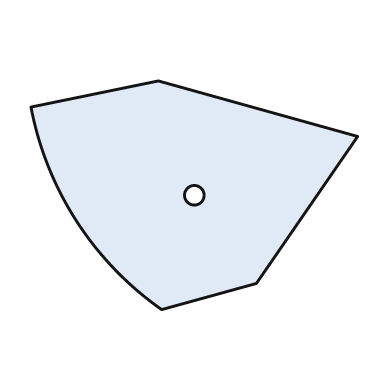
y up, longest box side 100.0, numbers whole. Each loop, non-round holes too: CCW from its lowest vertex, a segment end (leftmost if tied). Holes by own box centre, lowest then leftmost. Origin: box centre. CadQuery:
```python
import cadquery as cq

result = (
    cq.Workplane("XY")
    .moveTo(-10.0, -35.0)
    .lineTo(19.0, -27.0)
    .lineTo(50.0, 18.0)
    .lineTo(-11.0, 35.0)
    .lineTo(-50.0, 27.0)
    .threePointArc((-36.0, -8.0), (-10.0, -35.0))
    .close()
    .moveTo(0.0, 0.0)
    .circle(3.0)
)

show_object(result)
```